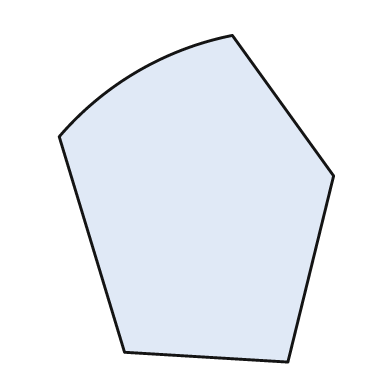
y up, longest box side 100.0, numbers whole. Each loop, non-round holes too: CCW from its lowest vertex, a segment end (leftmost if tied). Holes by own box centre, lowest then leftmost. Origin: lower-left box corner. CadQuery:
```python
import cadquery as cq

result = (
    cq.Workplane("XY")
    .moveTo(70.0, 0.0)
    .lineTo(84.0, 57.0)
    .lineTo(53.0, 100.0)
    .threePointArc((24.0, 89.0), (0.0, 69.0))
    .lineTo(20.0, 3.0)
    .close()
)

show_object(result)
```